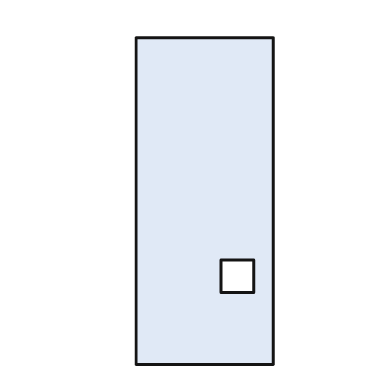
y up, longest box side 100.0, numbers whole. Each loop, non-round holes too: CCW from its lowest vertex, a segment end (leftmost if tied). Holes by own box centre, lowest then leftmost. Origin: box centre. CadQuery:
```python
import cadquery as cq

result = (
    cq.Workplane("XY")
    .moveTo(-21.0, -50.0)
    .lineTo(21.0, -50.0)
    .lineTo(21.0, 50.0)
    .lineTo(-21.0, 50.0)
    .close()
    .moveTo(5.0, -28.0)
    .lineTo(15.0, -28.0)
    .lineTo(15.0, -18.0)
    .lineTo(5.0, -18.0)
    .close()
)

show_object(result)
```